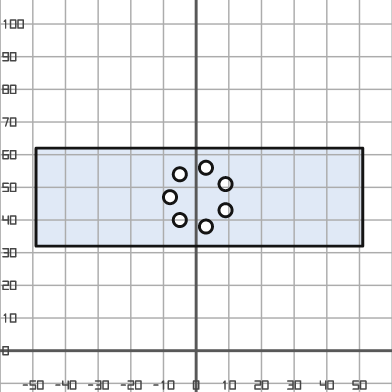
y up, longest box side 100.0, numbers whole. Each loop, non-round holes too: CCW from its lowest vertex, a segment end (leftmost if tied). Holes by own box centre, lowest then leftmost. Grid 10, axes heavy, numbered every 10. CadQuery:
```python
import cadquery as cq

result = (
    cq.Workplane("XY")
    .moveTo(-49.0, 32.0)
    .lineTo(51.0, 32.0)
    .lineTo(51.0, 62.0)
    .lineTo(-49.0, 62.0)
    .close()
    .moveTo(3.0, 38.0)
    .circle(2.0)
    .moveTo(-5.0, 40.0)
    .circle(2.0)
    .moveTo(9.0, 43.0)
    .circle(2.0)
    .moveTo(-8.0, 47.0)
    .circle(2.0)
    .moveTo(9.0, 51.0)
    .circle(2.0)
    .moveTo(-5.0, 54.0)
    .circle(2.0)
    .moveTo(3.0, 56.0)
    .circle(2.0)
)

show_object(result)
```